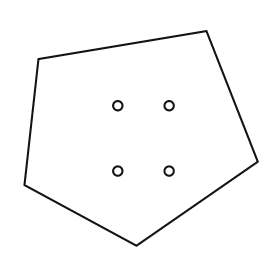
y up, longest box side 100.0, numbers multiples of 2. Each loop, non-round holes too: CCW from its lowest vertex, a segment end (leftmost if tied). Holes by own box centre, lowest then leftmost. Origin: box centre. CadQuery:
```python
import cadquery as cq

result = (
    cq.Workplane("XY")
    .moveTo(-2.0, -46.0)
    .lineTo(50.0, -10.0)
    .lineTo(28.0, 46.0)
    .lineTo(-44.0, 34.0)
    .lineTo(-50.0, -20.0)
    .close()
    .moveTo(-10.0, -14.0)
    .circle(2.0)
    .moveTo(12.0, -14.0)
    .circle(2.0)
    .moveTo(-10.0, 14.0)
    .circle(2.0)
    .moveTo(12.0, 14.0)
    .circle(2.0)
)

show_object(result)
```